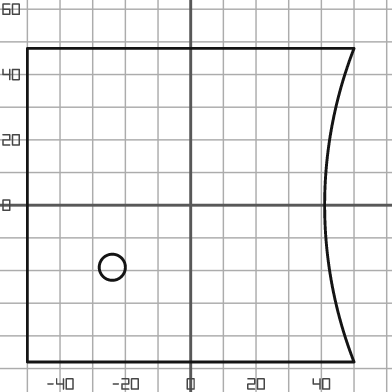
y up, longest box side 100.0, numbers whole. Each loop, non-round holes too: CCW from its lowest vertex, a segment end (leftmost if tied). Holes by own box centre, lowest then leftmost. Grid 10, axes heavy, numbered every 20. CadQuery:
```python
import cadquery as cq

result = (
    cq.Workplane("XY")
    .moveTo(-50.0, -48.0)
    .lineTo(50.0, -48.0)
    .threePointArc((41.0, 0.0), (50.0, 48.0))
    .lineTo(-50.0, 48.0)
    .close()
    .moveTo(-24.0, -19.0)
    .circle(4.0)
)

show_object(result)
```